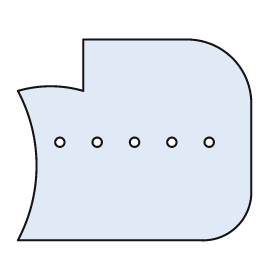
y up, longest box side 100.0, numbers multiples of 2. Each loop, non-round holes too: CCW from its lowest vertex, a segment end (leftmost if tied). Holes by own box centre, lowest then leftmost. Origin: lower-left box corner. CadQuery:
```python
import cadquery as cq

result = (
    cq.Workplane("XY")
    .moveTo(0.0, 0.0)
    .lineTo(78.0, 0.0)
    .threePointArc((94.0, 6.0), (100.0, 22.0))
    .lineTo(100.0, 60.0)
    .threePointArc((92.0, 78.0), (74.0, 86.0))
    .lineTo(28.0, 86.0)
    .lineTo(28.0, 64.0)
    .threePointArc((14.0, 66.0), (0.0, 64.0))
    .threePointArc((8.0, 32.0), (0.0, 0.0))
    .close()
    .moveTo(18.0, 42.0)
    .circle(2.0)
    .moveTo(34.0, 42.0)
    .circle(2.0)
    .moveTo(50.0, 42.0)
    .circle(2.0)
    .moveTo(66.0, 42.0)
    .circle(2.0)
    .moveTo(82.0, 42.0)
    .circle(2.0)
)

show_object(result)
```